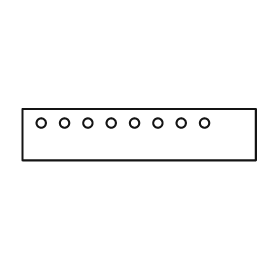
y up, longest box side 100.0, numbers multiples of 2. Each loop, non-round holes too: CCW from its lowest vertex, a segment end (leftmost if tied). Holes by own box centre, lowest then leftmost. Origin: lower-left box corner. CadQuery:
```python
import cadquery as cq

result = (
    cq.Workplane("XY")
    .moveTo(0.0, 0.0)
    .lineTo(100.0, 0.0)
    .lineTo(100.0, 22.0)
    .lineTo(0.0, 22.0)
    .close()
    .moveTo(8.0, 16.0)
    .circle(2.0)
    .moveTo(18.0, 16.0)
    .circle(2.0)
    .moveTo(28.0, 16.0)
    .circle(2.0)
    .moveTo(38.0, 16.0)
    .circle(2.0)
    .moveTo(48.0, 16.0)
    .circle(2.0)
    .moveTo(58.0, 16.0)
    .circle(2.0)
    .moveTo(68.0, 16.0)
    .circle(2.0)
    .moveTo(78.0, 16.0)
    .circle(2.0)
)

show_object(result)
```